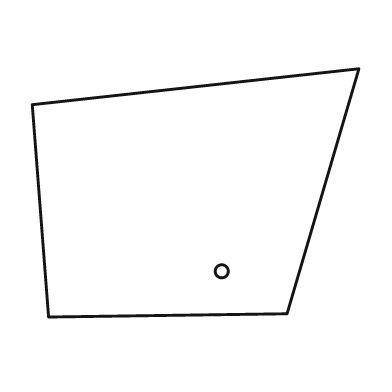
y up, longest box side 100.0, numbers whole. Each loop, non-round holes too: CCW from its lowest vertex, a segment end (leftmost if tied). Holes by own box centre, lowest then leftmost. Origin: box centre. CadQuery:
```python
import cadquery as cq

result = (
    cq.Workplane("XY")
    .moveTo(-45.0, -38.0)
    .lineTo(28.0, -37.0)
    .lineTo(50.0, 38.0)
    .lineTo(-50.0, 27.0)
    .close()
    .moveTo(8.0, -24.0)
    .circle(2.0)
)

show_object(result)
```